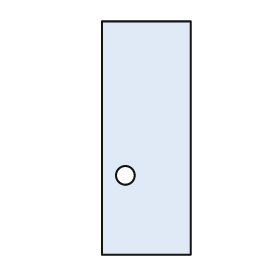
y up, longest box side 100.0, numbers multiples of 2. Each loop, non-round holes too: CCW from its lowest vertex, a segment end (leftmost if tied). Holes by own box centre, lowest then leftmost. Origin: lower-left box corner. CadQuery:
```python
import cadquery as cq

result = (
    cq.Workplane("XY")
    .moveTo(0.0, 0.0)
    .lineTo(38.0, 0.0)
    .lineTo(38.0, 100.0)
    .lineTo(0.0, 100.0)
    .close()
    .moveTo(10.0, 34.0)
    .circle(4.0)
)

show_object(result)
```